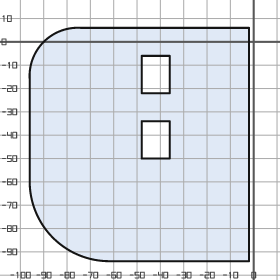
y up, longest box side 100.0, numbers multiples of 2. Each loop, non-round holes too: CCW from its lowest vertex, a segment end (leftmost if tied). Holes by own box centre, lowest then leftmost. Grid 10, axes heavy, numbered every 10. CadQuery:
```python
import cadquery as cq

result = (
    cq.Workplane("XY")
    .moveTo(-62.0, -94.0)
    .lineTo(-2.0, -94.0)
    .lineTo(-2.0, 6.0)
    .lineTo(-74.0, 6.0)
    .threePointArc((-90.0, 0.0), (-96.0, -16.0))
    .lineTo(-96.0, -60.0)
    .threePointArc((-86.0, -84.0), (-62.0, -94.0))
    .close()
    .moveTo(-48.0, -50.0)
    .lineTo(-36.0, -50.0)
    .lineTo(-36.0, -34.0)
    .lineTo(-48.0, -34.0)
    .close()
    .moveTo(-48.0, -22.0)
    .lineTo(-36.0, -22.0)
    .lineTo(-36.0, -6.0)
    .lineTo(-48.0, -6.0)
    .close()
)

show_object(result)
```